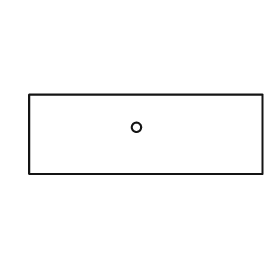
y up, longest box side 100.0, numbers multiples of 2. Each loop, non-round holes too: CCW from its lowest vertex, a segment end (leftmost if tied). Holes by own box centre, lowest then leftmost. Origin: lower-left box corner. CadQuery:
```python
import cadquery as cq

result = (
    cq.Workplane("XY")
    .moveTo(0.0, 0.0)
    .lineTo(100.0, 0.0)
    .lineTo(100.0, 34.0)
    .lineTo(0.0, 34.0)
    .close()
    .moveTo(46.0, 20.0)
    .circle(2.0)
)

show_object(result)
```